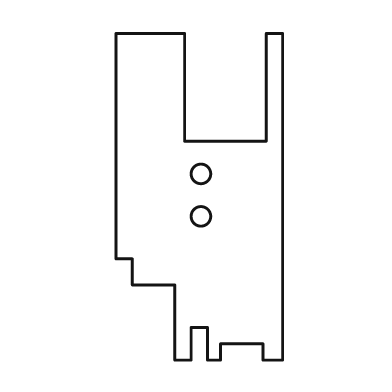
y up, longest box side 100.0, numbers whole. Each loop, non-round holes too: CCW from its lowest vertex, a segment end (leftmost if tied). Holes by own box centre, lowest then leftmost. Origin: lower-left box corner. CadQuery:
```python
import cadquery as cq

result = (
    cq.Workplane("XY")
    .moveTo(18.0, 0.0)
    .lineTo(23.0, 0.0)
    .lineTo(23.0, 10.0)
    .lineTo(28.0, 10.0)
    .lineTo(28.0, 0.0)
    .lineTo(32.0, 0.0)
    .lineTo(32.0, 5.0)
    .lineTo(45.0, 5.0)
    .lineTo(45.0, 0.0)
    .lineTo(51.0, 0.0)
    .lineTo(51.0, 100.0)
    .lineTo(46.0, 100.0)
    .lineTo(46.0, 67.0)
    .lineTo(21.0, 67.0)
    .lineTo(21.0, 100.0)
    .lineTo(0.0, 100.0)
    .lineTo(0.0, 31.0)
    .lineTo(5.0, 31.0)
    .lineTo(5.0, 23.0)
    .lineTo(18.0, 23.0)
    .close()
    .moveTo(26.0, 44.0)
    .circle(3.0)
    .moveTo(26.0, 57.0)
    .circle(3.0)
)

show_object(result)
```